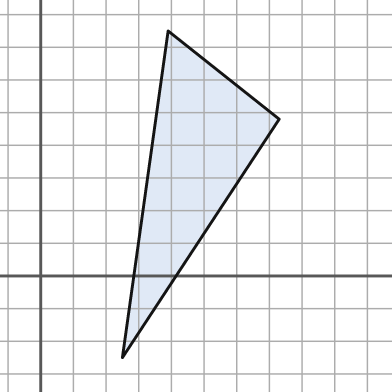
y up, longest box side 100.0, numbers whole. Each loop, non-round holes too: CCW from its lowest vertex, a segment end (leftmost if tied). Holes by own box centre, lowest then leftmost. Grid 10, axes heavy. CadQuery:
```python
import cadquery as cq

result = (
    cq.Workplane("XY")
    .moveTo(25.0, -25.0)
    .lineTo(73.0, 48.0)
    .lineTo(39.0, 75.0)
    .close()
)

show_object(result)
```